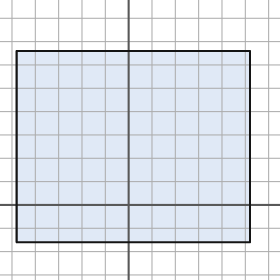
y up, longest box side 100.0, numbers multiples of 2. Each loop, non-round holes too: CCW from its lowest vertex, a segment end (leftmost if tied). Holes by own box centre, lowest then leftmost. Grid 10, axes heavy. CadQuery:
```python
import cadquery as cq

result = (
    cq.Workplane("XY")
    .moveTo(-48.0, -16.0)
    .lineTo(52.0, -16.0)
    .lineTo(52.0, 66.0)
    .lineTo(-48.0, 66.0)
    .close()
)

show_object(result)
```